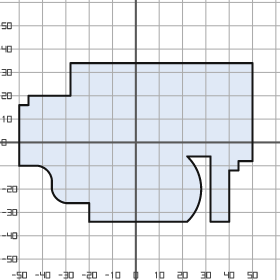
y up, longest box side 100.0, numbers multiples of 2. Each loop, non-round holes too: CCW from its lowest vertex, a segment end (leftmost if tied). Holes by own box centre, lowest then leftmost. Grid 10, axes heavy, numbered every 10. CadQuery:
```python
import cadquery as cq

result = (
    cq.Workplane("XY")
    .moveTo(-20.0, -34.0)
    .lineTo(22.0, -34.0)
    .threePointArc((28.0, -20.0), (22.0, -6.0))
    .lineTo(32.0, -6.0)
    .lineTo(32.0, -34.0)
    .lineTo(40.0, -34.0)
    .lineTo(40.0, -12.0)
    .lineTo(44.0, -12.0)
    .lineTo(44.0, -8.0)
    .lineTo(50.0, -8.0)
    .lineTo(50.0, 34.0)
    .lineTo(-28.0, 34.0)
    .lineTo(-28.0, 20.0)
    .lineTo(-46.0, 20.0)
    .lineTo(-46.0, 16.0)
    .lineTo(-50.0, 16.0)
    .lineTo(-50.0, -10.0)
    .lineTo(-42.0, -10.0)
    .threePointArc((-38.0, -12.0), (-36.0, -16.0))
    .lineTo(-36.0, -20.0)
    .threePointArc((-34.0, -24.0), (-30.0, -26.0))
    .lineTo(-20.0, -26.0)
    .close()
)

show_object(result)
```